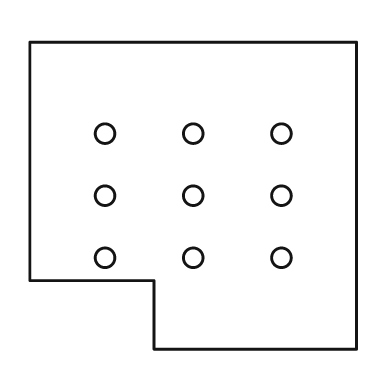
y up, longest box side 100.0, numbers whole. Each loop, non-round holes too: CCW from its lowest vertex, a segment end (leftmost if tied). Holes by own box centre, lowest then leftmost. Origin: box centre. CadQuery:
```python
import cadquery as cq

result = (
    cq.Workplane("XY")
    .moveTo(-12.0, -47.0)
    .lineTo(50.0, -47.0)
    .lineTo(50.0, 47.0)
    .lineTo(-50.0, 47.0)
    .lineTo(-50.0, -26.0)
    .lineTo(-12.0, -26.0)
    .close()
    .moveTo(-27.0, -19.0)
    .circle(3.0)
    .moveTo(0.0, -19.0)
    .circle(3.0)
    .moveTo(27.0, -19.0)
    .circle(3.0)
    .moveTo(-27.0, 0.0)
    .circle(3.0)
    .moveTo(0.0, 0.0)
    .circle(3.0)
    .moveTo(27.0, 0.0)
    .circle(3.0)
    .moveTo(-27.0, 19.0)
    .circle(3.0)
    .moveTo(0.0, 19.0)
    .circle(3.0)
    .moveTo(27.0, 19.0)
    .circle(3.0)
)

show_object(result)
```